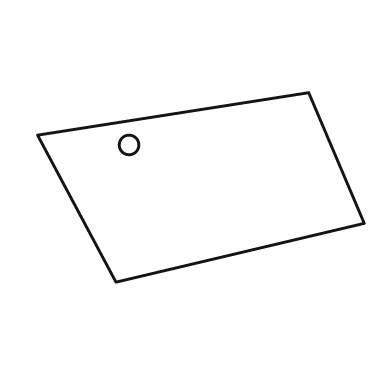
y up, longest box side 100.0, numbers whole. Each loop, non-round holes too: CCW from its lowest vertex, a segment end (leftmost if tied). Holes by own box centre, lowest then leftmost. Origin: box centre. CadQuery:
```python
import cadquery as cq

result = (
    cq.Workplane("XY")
    .moveTo(-26.0, -29.0)
    .lineTo(50.0, -11.0)
    .lineTo(33.0, 29.0)
    .lineTo(-50.0, 16.0)
    .close()
    .moveTo(-22.0, 13.0)
    .circle(3.0)
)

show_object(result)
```